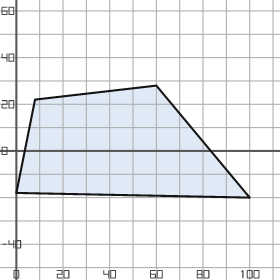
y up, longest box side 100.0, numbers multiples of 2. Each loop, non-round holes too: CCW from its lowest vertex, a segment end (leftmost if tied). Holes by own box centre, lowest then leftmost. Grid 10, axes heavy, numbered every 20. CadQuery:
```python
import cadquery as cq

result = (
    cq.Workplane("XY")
    .moveTo(100.0, -20.0)
    .lineTo(60.0, 28.0)
    .lineTo(8.0, 22.0)
    .lineTo(0.0, -18.0)
    .close()
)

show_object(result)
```